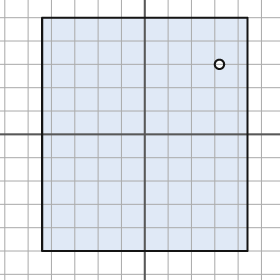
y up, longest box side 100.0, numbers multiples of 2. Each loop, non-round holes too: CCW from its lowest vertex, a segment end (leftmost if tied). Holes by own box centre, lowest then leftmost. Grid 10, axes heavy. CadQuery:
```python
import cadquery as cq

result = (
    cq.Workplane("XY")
    .moveTo(-44.0, -50.0)
    .lineTo(44.0, -50.0)
    .lineTo(44.0, 50.0)
    .lineTo(-44.0, 50.0)
    .close()
    .moveTo(32.0, 30.0)
    .circle(2.0)
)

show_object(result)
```